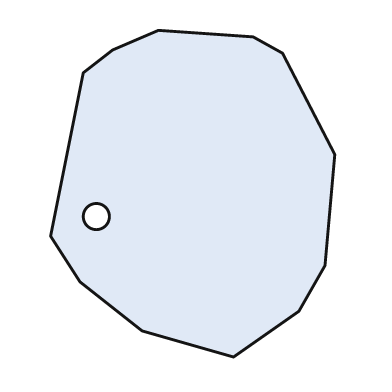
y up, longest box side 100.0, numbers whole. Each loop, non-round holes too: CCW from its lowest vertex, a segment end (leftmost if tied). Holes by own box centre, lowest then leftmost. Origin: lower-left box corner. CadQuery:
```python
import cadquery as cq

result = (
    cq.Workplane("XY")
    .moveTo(56.0, 0.0)
    .lineTo(76.0, 14.0)
    .lineTo(84.0, 28.0)
    .lineTo(87.0, 62.0)
    .lineTo(71.0, 93.0)
    .lineTo(62.0, 98.0)
    .lineTo(33.0, 100.0)
    .lineTo(19.0, 94.0)
    .lineTo(10.0, 87.0)
    .lineTo(0.0, 37.0)
    .lineTo(9.0, 23.0)
    .lineTo(28.0, 8.0)
    .close()
    .moveTo(14.0, 43.0)
    .circle(4.0)
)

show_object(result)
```